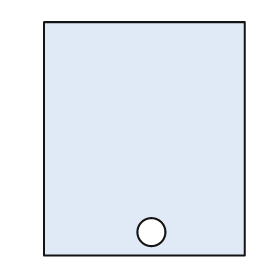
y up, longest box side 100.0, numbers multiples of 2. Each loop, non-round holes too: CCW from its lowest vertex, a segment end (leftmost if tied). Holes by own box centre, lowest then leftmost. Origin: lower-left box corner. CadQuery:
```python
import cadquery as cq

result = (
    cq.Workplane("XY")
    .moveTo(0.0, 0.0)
    .lineTo(86.0, 0.0)
    .lineTo(86.0, 100.0)
    .lineTo(0.0, 100.0)
    .close()
    .moveTo(46.0, 10.0)
    .circle(6.0)
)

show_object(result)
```